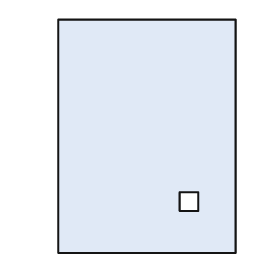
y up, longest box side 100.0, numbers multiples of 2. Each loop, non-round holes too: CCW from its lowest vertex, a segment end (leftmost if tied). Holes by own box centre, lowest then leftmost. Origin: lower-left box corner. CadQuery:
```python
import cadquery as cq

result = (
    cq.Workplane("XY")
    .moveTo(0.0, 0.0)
    .lineTo(76.0, 0.0)
    .lineTo(76.0, 100.0)
    .lineTo(0.0, 100.0)
    .close()
    .moveTo(52.0, 18.0)
    .lineTo(60.0, 18.0)
    .lineTo(60.0, 26.0)
    .lineTo(52.0, 26.0)
    .close()
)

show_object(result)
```